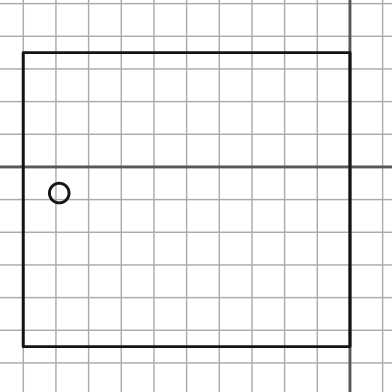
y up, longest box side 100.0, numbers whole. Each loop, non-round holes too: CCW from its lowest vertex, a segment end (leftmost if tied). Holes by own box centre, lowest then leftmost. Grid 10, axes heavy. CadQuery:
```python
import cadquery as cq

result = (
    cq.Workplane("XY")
    .moveTo(-100.0, -55.0)
    .lineTo(0.0, -55.0)
    .lineTo(0.0, 35.0)
    .lineTo(-100.0, 35.0)
    .close()
    .moveTo(-89.0, -8.0)
    .circle(3.0)
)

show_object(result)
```